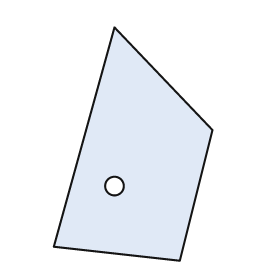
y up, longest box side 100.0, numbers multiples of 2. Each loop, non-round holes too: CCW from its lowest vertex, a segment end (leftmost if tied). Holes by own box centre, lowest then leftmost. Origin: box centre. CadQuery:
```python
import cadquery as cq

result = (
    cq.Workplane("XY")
    .moveTo(20.0, -50.0)
    .lineTo(34.0, 6.0)
    .lineTo(-8.0, 50.0)
    .lineTo(-34.0, -44.0)
    .close()
    .moveTo(-8.0, -18.0)
    .circle(4.0)
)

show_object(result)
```